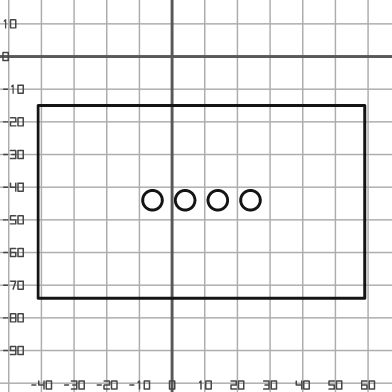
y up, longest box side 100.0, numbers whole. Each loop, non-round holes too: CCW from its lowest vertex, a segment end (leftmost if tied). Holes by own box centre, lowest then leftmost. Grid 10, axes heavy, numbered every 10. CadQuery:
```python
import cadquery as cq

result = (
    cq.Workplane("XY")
    .moveTo(-41.0, -74.0)
    .lineTo(59.0, -74.0)
    .lineTo(59.0, -15.0)
    .lineTo(-41.0, -15.0)
    .close()
    .moveTo(-6.0, -44.0)
    .circle(3.0)
    .moveTo(4.0, -44.0)
    .circle(3.0)
    .moveTo(14.0, -44.0)
    .circle(3.0)
    .moveTo(24.0, -44.0)
    .circle(3.0)
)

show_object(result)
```